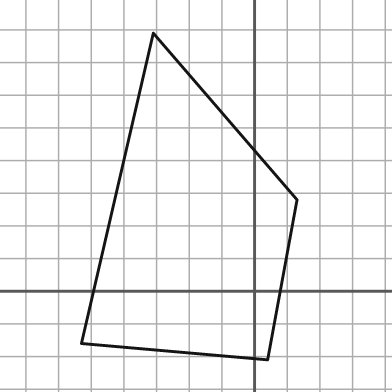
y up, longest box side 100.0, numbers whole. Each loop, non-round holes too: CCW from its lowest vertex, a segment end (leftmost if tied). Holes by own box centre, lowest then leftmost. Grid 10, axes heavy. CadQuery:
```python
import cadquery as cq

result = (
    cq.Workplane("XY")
    .moveTo(4.0, -21.0)
    .lineTo(13.0, 28.0)
    .lineTo(-31.0, 79.0)
    .lineTo(-53.0, -16.0)
    .close()
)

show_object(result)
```